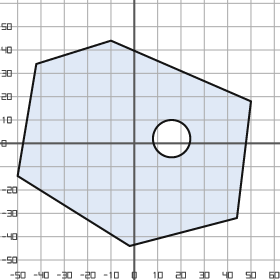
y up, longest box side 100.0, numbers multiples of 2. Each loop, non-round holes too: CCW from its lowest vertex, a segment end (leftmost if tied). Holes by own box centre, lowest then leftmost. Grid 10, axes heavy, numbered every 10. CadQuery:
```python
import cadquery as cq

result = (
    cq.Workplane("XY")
    .moveTo(-2.0, -44.0)
    .lineTo(44.0, -32.0)
    .lineTo(50.0, 18.0)
    .lineTo(-10.0, 44.0)
    .lineTo(-42.0, 34.0)
    .lineTo(-50.0, -14.0)
    .close()
    .moveTo(16.0, 2.0)
    .circle(8.0)
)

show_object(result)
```